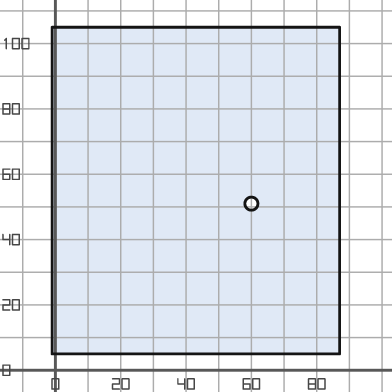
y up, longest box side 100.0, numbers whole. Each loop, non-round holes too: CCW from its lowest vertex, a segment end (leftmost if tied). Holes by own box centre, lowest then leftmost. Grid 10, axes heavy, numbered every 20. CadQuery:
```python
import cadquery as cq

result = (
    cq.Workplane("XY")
    .moveTo(-1.0, 5.0)
    .lineTo(87.0, 5.0)
    .lineTo(87.0, 105.0)
    .lineTo(-1.0, 105.0)
    .close()
    .moveTo(60.0, 51.0)
    .circle(2.0)
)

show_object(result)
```